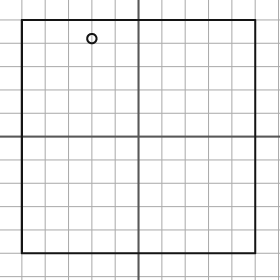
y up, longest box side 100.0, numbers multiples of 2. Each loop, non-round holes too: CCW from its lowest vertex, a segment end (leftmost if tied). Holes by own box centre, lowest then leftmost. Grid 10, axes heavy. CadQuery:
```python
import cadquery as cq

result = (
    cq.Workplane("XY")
    .moveTo(-50.0, -50.0)
    .lineTo(50.0, -50.0)
    .lineTo(50.0, 50.0)
    .lineTo(-50.0, 50.0)
    .close()
    .moveTo(-20.0, 42.0)
    .circle(2.0)
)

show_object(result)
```